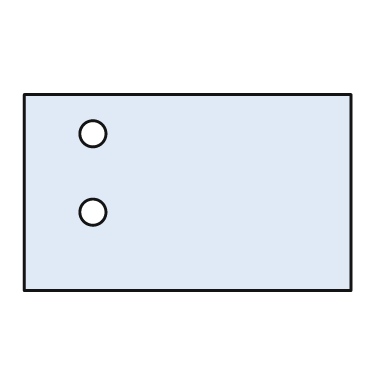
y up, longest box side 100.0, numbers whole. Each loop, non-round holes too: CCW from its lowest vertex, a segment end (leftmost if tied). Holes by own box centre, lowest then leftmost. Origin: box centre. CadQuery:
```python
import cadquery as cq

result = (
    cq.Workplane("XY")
    .moveTo(-50.0, -30.0)
    .lineTo(50.0, -30.0)
    .lineTo(50.0, 30.0)
    .lineTo(-50.0, 30.0)
    .close()
    .moveTo(-29.0, -6.0)
    .circle(4.0)
    .moveTo(-29.0, 18.0)
    .circle(4.0)
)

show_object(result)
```